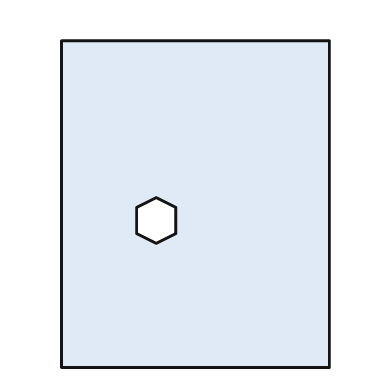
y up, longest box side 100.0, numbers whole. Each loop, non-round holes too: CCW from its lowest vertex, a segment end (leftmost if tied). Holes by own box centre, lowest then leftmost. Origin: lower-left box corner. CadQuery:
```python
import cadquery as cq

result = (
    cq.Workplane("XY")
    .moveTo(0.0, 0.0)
    .lineTo(82.0, 0.0)
    .lineTo(82.0, 100.0)
    .lineTo(0.0, 100.0)
    .close()
    .moveTo(29.0, 38.0)
    .lineTo(35.0, 41.0)
    .lineTo(35.0, 49.0)
    .lineTo(29.0, 52.0)
    .lineTo(23.0, 49.0)
    .lineTo(23.0, 41.0)
    .close()
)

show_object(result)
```